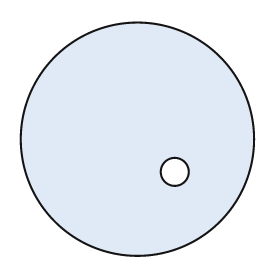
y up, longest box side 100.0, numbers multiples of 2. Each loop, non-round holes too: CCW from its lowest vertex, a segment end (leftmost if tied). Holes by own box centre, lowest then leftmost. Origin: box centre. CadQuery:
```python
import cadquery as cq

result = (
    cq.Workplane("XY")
    .moveTo(0.0, 0.0)
    .circle(50.0)
    .moveTo(16.0, -14.0)
    .circle(6.0)
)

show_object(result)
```